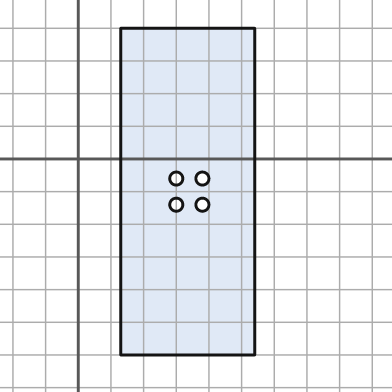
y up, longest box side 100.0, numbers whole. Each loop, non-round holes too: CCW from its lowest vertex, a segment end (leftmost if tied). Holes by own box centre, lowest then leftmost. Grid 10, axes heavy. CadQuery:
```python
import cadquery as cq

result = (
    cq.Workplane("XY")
    .moveTo(13.0, -60.0)
    .lineTo(54.0, -60.0)
    .lineTo(54.0, 40.0)
    .lineTo(13.0, 40.0)
    .close()
    .moveTo(30.0, -14.0)
    .circle(2.0)
    .moveTo(38.0, -14.0)
    .circle(2.0)
    .moveTo(30.0, -6.0)
    .circle(2.0)
    .moveTo(38.0, -6.0)
    .circle(2.0)
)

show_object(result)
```